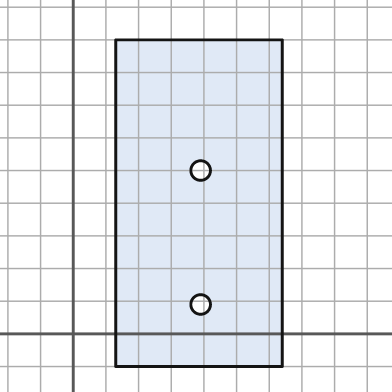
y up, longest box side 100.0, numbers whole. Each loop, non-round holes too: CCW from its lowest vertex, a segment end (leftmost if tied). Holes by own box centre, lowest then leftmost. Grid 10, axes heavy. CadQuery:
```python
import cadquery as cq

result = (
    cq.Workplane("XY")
    .moveTo(13.0, -10.0)
    .lineTo(64.0, -10.0)
    .lineTo(64.0, 90.0)
    .lineTo(13.0, 90.0)
    .close()
    .moveTo(39.0, 9.0)
    .circle(3.0)
    .moveTo(39.0, 50.0)
    .circle(3.0)
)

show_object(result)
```